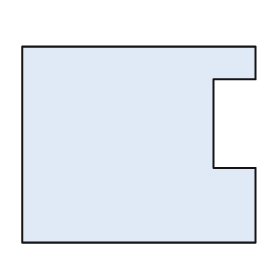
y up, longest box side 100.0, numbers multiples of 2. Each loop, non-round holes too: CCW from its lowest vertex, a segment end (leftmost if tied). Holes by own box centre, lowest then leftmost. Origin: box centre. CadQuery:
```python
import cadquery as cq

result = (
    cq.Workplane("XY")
    .moveTo(-50.0, -42.0)
    .lineTo(50.0, -42.0)
    .lineTo(50.0, -10.0)
    .lineTo(32.0, -10.0)
    .lineTo(32.0, 28.0)
    .lineTo(50.0, 28.0)
    .lineTo(50.0, 42.0)
    .lineTo(-50.0, 42.0)
    .close()
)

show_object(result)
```